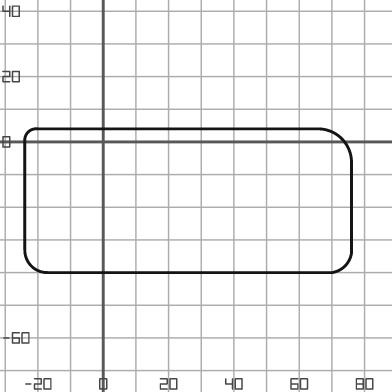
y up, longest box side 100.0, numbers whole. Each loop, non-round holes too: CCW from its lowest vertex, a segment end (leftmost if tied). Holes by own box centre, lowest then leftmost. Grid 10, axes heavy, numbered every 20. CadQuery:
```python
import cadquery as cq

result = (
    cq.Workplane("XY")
    .moveTo(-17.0, -40.0)
    .lineTo(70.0, -40.0)
    .threePointArc((74.0, -38.0), (76.0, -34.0))
    .lineTo(76.0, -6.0)
    .threePointArc((73.0, 1.0), (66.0, 4.0))
    .lineTo(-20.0, 4.0)
    .threePointArc((-23.0, 3.0), (-24.0, 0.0))
    .lineTo(-24.0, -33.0)
    .threePointArc((-22.0, -38.0), (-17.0, -40.0))
    .close()
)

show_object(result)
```